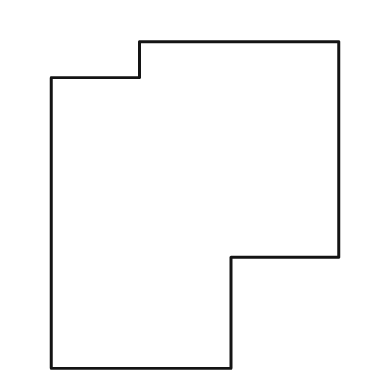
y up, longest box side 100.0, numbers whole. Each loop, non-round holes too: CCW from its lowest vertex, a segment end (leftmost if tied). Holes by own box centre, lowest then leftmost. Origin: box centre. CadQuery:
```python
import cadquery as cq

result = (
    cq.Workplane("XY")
    .moveTo(-44.0, -50.0)
    .lineTo(11.0, -50.0)
    .lineTo(11.0, -16.0)
    .lineTo(44.0, -16.0)
    .lineTo(44.0, 50.0)
    .lineTo(-17.0, 50.0)
    .lineTo(-17.0, 39.0)
    .lineTo(-44.0, 39.0)
    .close()
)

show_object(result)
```